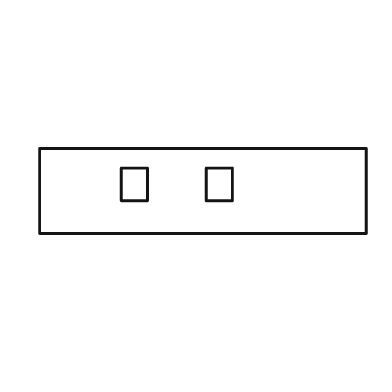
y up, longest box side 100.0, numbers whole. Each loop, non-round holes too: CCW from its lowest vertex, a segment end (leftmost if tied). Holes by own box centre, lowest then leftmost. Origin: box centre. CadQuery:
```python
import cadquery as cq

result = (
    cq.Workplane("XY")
    .moveTo(-50.0, -13.0)
    .lineTo(50.0, -13.0)
    .lineTo(50.0, 13.0)
    .lineTo(-50.0, 13.0)
    .close()
    .moveTo(-25.0, -3.0)
    .lineTo(-17.0, -3.0)
    .lineTo(-17.0, 7.0)
    .lineTo(-25.0, 7.0)
    .close()
    .moveTo(1.0, -3.0)
    .lineTo(9.0, -3.0)
    .lineTo(9.0, 7.0)
    .lineTo(1.0, 7.0)
    .close()
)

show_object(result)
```